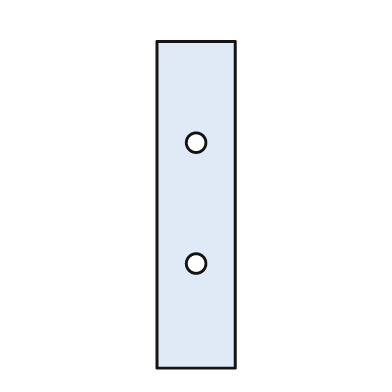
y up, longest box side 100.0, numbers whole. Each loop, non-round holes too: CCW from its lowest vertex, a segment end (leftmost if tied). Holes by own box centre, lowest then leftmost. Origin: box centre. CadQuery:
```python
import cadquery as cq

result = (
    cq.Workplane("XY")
    .moveTo(-12.0, -50.0)
    .lineTo(12.0, -50.0)
    .lineTo(12.0, 50.0)
    .lineTo(-12.0, 50.0)
    .close()
    .moveTo(0.0, -18.0)
    .circle(3.0)
    .moveTo(0.0, 19.0)
    .circle(3.0)
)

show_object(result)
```